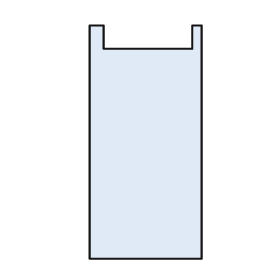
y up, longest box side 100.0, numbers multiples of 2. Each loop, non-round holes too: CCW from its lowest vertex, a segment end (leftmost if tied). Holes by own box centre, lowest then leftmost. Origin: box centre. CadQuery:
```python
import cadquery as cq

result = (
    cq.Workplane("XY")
    .moveTo(-24.0, -50.0)
    .lineTo(24.0, -50.0)
    .lineTo(24.0, 50.0)
    .lineTo(20.0, 50.0)
    .lineTo(20.0, 40.0)
    .lineTo(-18.0, 40.0)
    .lineTo(-18.0, 50.0)
    .lineTo(-24.0, 50.0)
    .close()
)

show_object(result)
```